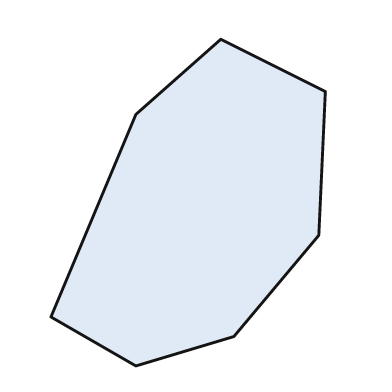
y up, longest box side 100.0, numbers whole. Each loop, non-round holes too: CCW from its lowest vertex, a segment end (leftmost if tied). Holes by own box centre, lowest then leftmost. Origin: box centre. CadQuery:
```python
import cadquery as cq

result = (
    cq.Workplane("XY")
    .moveTo(-16.0, -50.0)
    .lineTo(14.0, -41.0)
    .lineTo(40.0, -10.0)
    .lineTo(42.0, 34.0)
    .lineTo(10.0, 50.0)
    .lineTo(-16.0, 27.0)
    .lineTo(-42.0, -35.0)
    .close()
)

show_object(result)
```